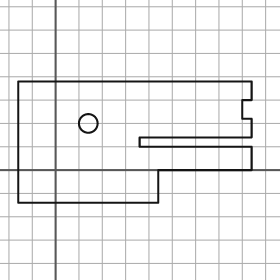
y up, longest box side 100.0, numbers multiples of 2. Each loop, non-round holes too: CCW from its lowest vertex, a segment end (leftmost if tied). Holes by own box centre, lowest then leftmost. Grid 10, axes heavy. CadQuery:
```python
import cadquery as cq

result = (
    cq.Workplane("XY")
    .moveTo(-16.0, -14.0)
    .lineTo(44.0, -14.0)
    .lineTo(44.0, 0.0)
    .lineTo(84.0, 0.0)
    .lineTo(84.0, 10.0)
    .lineTo(36.0, 10.0)
    .lineTo(36.0, 14.0)
    .lineTo(84.0, 14.0)
    .lineTo(84.0, 22.0)
    .lineTo(80.0, 22.0)
    .lineTo(80.0, 30.0)
    .lineTo(84.0, 30.0)
    .lineTo(84.0, 38.0)
    .lineTo(-16.0, 38.0)
    .close()
    .moveTo(14.0, 20.0)
    .circle(4.0)
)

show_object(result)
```